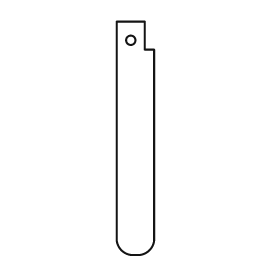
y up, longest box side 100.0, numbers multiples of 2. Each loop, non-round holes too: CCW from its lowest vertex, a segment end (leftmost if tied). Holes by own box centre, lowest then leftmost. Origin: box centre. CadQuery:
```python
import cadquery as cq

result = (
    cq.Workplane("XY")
    .moveTo(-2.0, -50.0)
    .lineTo(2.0, -50.0)
    .threePointArc((6.0, -48.0), (8.0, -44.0))
    .lineTo(8.0, 38.0)
    .lineTo(4.0, 38.0)
    .lineTo(4.0, 50.0)
    .lineTo(-8.0, 50.0)
    .lineTo(-8.0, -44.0)
    .threePointArc((-6.0, -48.0), (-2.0, -50.0))
    .close()
    .moveTo(-2.0, 42.0)
    .circle(2.0)
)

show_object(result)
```